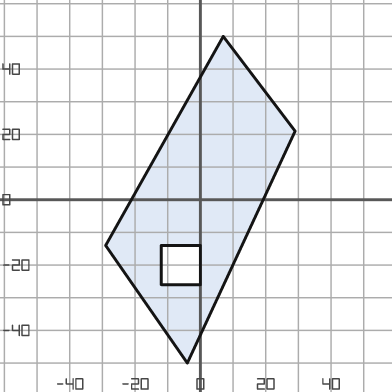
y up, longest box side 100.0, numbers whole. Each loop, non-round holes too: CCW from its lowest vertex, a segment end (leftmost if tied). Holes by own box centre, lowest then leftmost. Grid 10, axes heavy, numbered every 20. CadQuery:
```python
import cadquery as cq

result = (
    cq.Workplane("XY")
    .moveTo(-4.0, -50.0)
    .lineTo(29.0, 21.0)
    .lineTo(7.0, 50.0)
    .lineTo(-29.0, -14.0)
    .close()
    .moveTo(-12.0, -26.0)
    .lineTo(0.0, -26.0)
    .lineTo(0.0, -14.0)
    .lineTo(-12.0, -14.0)
    .close()
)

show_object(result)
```